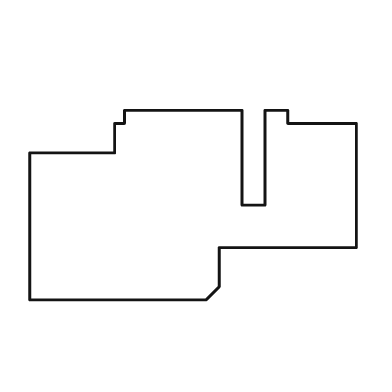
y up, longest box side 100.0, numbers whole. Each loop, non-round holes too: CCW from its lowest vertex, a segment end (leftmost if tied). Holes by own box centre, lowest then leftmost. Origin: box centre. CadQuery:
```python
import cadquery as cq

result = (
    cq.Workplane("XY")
    .moveTo(-50.0, -29.0)
    .lineTo(4.0, -29.0)
    .lineTo(8.0, -25.0)
    .lineTo(8.0, -13.0)
    .lineTo(50.0, -13.0)
    .lineTo(50.0, 25.0)
    .lineTo(29.0, 25.0)
    .lineTo(29.0, 29.0)
    .lineTo(22.0, 29.0)
    .lineTo(22.0, 0.0)
    .lineTo(15.0, 0.0)
    .lineTo(15.0, 29.0)
    .lineTo(-21.0, 29.0)
    .lineTo(-21.0, 25.0)
    .lineTo(-24.0, 25.0)
    .lineTo(-24.0, 16.0)
    .lineTo(-50.0, 16.0)
    .close()
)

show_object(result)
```